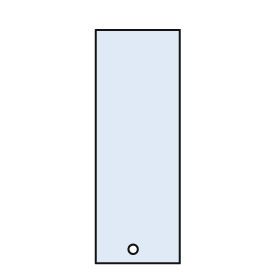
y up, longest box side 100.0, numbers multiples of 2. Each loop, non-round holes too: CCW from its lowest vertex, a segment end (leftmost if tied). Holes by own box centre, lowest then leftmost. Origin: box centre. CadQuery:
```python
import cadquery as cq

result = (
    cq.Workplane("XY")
    .moveTo(-18.0, -50.0)
    .lineTo(18.0, -50.0)
    .lineTo(18.0, 50.0)
    .lineTo(-18.0, 50.0)
    .close()
    .moveTo(-2.0, -44.0)
    .circle(2.0)
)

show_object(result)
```